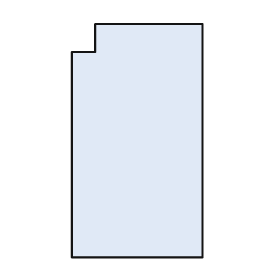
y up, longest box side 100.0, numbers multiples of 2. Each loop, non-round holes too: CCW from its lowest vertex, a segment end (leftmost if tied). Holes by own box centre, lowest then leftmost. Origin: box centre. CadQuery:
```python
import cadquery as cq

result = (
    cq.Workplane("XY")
    .moveTo(-28.0, -50.0)
    .lineTo(28.0, -50.0)
    .lineTo(28.0, 50.0)
    .lineTo(-18.0, 50.0)
    .lineTo(-18.0, 38.0)
    .lineTo(-28.0, 38.0)
    .close()
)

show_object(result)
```